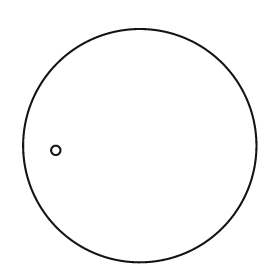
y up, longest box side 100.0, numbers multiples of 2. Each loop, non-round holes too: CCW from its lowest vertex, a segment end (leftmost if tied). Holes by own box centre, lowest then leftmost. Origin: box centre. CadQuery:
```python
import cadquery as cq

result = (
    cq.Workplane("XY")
    .moveTo(0.0, 0.0)
    .circle(50.0)
    .moveTo(-36.0, -2.0)
    .circle(2.0)
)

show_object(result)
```